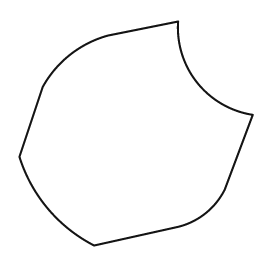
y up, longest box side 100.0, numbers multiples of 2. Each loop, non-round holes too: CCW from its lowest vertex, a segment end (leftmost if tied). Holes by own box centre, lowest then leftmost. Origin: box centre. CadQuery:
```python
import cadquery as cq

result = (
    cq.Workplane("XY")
    .moveTo(-18.0, -48.0)
    .lineTo(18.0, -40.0)
    .threePointArc((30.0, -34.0), (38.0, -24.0))
    .lineTo(50.0, 8.0)
    .threePointArc((26.0, 22.0), (18.0, 48.0))
    .lineTo(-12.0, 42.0)
    .threePointArc((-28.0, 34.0), (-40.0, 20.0))
    .lineTo(-50.0, -10.0)
    .threePointArc((-38.0, -32.0), (-18.0, -48.0))
    .close()
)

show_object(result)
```